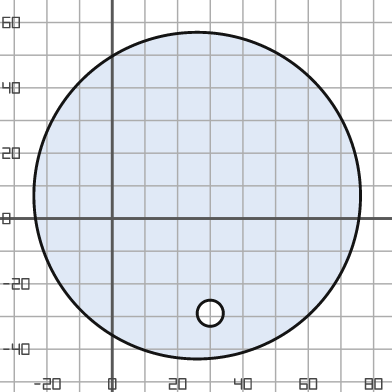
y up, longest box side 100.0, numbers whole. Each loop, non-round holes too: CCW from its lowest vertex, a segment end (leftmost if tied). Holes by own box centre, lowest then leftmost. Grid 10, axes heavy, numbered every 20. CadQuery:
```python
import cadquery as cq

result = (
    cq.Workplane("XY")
    .moveTo(26.0, 7.0)
    .circle(50.0)
    .moveTo(30.0, -29.0)
    .circle(4.0)
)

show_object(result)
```